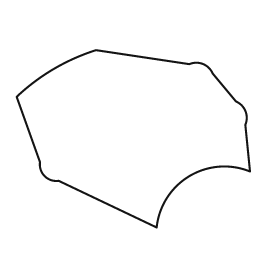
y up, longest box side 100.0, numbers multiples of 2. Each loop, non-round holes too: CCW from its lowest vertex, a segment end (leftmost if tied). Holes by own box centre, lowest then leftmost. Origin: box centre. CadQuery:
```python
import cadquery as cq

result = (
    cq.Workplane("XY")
    .moveTo(10.0, -38.0)
    .threePointArc((24.0, -16.0), (50.0, -14.0))
    .lineTo(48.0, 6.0)
    .threePointArc((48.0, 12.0), (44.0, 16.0))
    .lineTo(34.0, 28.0)
    .threePointArc((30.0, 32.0), (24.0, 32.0))
    .lineTo(-16.0, 38.0)
    .threePointArc((-34.0, 30.0), (-50.0, 18.0))
    .lineTo(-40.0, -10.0)
    .threePointArc((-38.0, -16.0), (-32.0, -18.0))
    .close()
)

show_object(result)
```